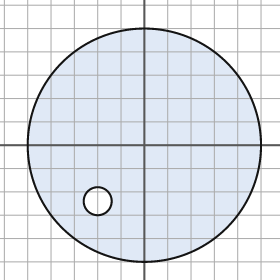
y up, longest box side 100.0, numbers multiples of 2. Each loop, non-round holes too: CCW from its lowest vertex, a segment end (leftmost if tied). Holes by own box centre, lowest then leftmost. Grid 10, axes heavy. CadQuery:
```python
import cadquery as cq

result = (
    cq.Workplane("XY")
    .moveTo(0.0, 0.0)
    .circle(50.0)
    .moveTo(-20.0, -24.0)
    .circle(6.0)
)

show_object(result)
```